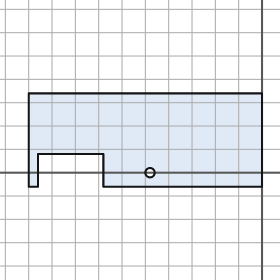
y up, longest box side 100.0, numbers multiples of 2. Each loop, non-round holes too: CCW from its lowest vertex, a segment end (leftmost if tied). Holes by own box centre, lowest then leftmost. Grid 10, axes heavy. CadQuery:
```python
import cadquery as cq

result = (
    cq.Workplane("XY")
    .moveTo(-100.0, -6.0)
    .lineTo(-96.0, -6.0)
    .lineTo(-96.0, 8.0)
    .lineTo(-68.0, 8.0)
    .lineTo(-68.0, -6.0)
    .lineTo(0.0, -6.0)
    .lineTo(0.0, 34.0)
    .lineTo(-100.0, 34.0)
    .close()
    .moveTo(-48.0, 0.0)
    .circle(2.0)
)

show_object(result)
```